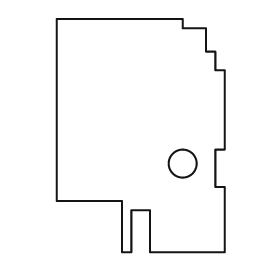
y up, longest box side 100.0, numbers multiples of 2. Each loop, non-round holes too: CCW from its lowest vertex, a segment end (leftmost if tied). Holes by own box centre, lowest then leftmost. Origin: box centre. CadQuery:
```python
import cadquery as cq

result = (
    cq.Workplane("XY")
    .moveTo(-8.0, -50.0)
    .lineTo(-4.0, -50.0)
    .lineTo(-4.0, -32.0)
    .lineTo(4.0, -32.0)
    .lineTo(4.0, -50.0)
    .lineTo(36.0, -50.0)
    .lineTo(36.0, -22.0)
    .lineTo(32.0, -22.0)
    .lineTo(32.0, -6.0)
    .lineTo(36.0, -6.0)
    .lineTo(36.0, 28.0)
    .lineTo(32.0, 28.0)
    .lineTo(32.0, 36.0)
    .lineTo(28.0, 36.0)
    .lineTo(28.0, 46.0)
    .lineTo(18.0, 46.0)
    .lineTo(18.0, 50.0)
    .lineTo(-36.0, 50.0)
    .lineTo(-36.0, -28.0)
    .lineTo(-8.0, -28.0)
    .close()
    .moveTo(18.0, -12.0)
    .circle(6.0)
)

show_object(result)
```